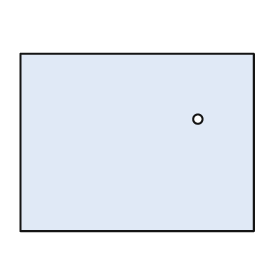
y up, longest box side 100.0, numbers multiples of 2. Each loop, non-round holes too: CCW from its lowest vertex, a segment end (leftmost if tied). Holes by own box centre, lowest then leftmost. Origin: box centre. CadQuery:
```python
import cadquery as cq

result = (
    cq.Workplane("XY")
    .moveTo(-50.0, -38.0)
    .lineTo(50.0, -38.0)
    .lineTo(50.0, 38.0)
    .lineTo(-50.0, 38.0)
    .close()
    .moveTo(26.0, 10.0)
    .circle(2.0)
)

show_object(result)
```